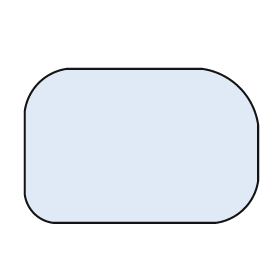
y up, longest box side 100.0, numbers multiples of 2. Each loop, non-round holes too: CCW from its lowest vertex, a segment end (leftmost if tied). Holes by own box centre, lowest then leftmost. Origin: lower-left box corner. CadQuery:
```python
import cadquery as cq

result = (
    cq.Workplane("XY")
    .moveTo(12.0, 0.0)
    .lineTo(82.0, 0.0)
    .threePointArc((94.0, 6.0), (100.0, 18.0))
    .lineTo(100.0, 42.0)
    .threePointArc((92.0, 58.0), (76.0, 66.0))
    .lineTo(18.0, 66.0)
    .threePointArc((6.0, 60.0), (0.0, 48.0))
    .lineTo(0.0, 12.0)
    .threePointArc((4.0, 4.0), (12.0, 0.0))
    .close()
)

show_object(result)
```